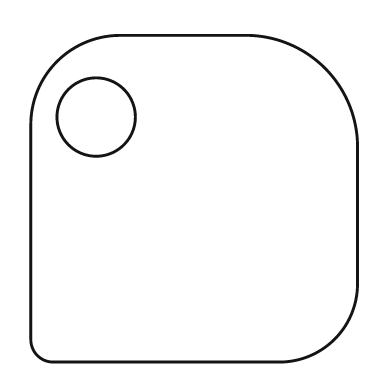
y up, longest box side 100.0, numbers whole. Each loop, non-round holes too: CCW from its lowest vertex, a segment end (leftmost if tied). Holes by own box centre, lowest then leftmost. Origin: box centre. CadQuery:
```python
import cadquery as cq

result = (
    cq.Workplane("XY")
    .moveTo(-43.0, -50.0)
    .lineTo(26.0, -50.0)
    .threePointArc((43.0, -43.0), (50.0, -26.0))
    .lineTo(50.0, 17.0)
    .threePointArc((40.0, 40.0), (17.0, 50.0))
    .lineTo(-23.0, 50.0)
    .threePointArc((-42.0, 42.0), (-50.0, 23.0))
    .lineTo(-50.0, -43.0)
    .threePointArc((-48.0, -48.0), (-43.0, -50.0))
    .close()
    .moveTo(-30.0, 25.0)
    .circle(12.0)
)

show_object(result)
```